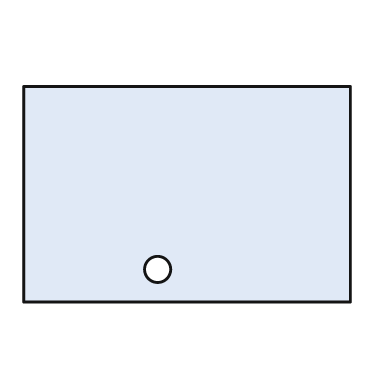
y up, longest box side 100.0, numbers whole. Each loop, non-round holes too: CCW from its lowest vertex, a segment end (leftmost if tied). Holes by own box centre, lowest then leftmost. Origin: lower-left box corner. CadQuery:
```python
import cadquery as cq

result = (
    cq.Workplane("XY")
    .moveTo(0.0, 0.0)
    .lineTo(100.0, 0.0)
    .lineTo(100.0, 66.0)
    .lineTo(0.0, 66.0)
    .close()
    .moveTo(41.0, 10.0)
    .circle(4.0)
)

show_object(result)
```